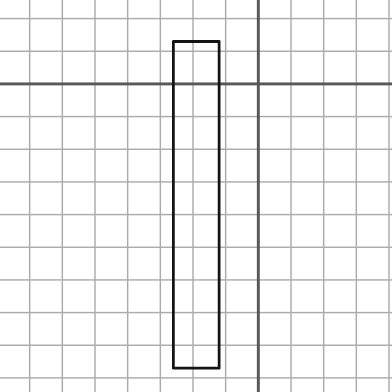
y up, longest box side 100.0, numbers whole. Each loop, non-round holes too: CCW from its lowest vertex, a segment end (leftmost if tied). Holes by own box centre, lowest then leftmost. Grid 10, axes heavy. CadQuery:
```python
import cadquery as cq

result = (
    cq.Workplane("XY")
    .moveTo(-26.0, -87.0)
    .lineTo(-12.0, -87.0)
    .lineTo(-12.0, 13.0)
    .lineTo(-26.0, 13.0)
    .close()
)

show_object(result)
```